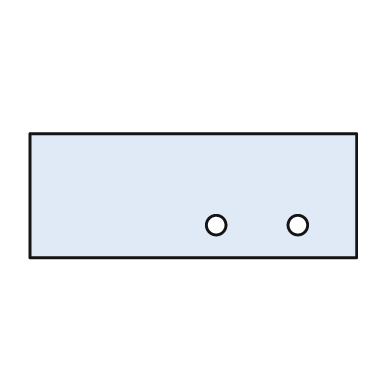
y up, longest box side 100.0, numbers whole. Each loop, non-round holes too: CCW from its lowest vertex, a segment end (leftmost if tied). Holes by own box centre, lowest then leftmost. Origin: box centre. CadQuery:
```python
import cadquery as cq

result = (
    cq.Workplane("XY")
    .moveTo(-50.0, -19.0)
    .lineTo(50.0, -19.0)
    .lineTo(50.0, 19.0)
    .lineTo(-50.0, 19.0)
    .close()
    .moveTo(7.0, -9.0)
    .circle(3.0)
    .moveTo(32.0, -9.0)
    .circle(3.0)
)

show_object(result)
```